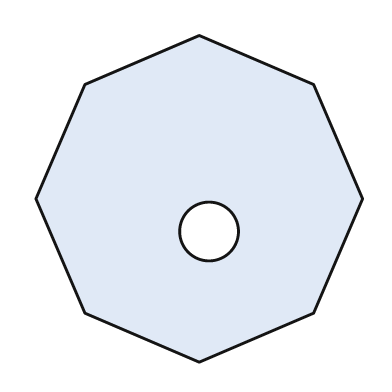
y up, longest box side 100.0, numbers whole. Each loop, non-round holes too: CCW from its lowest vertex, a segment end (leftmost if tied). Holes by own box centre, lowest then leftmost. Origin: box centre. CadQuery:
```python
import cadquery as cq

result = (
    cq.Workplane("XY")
    .moveTo(0.0, -50.0)
    .lineTo(35.0, -35.0)
    .lineTo(50.0, 0.0)
    .lineTo(35.0, 35.0)
    .lineTo(0.0, 50.0)
    .lineTo(-35.0, 35.0)
    .lineTo(-50.0, 0.0)
    .lineTo(-35.0, -35.0)
    .close()
    .moveTo(3.0, -10.0)
    .circle(9.0)
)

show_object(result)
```